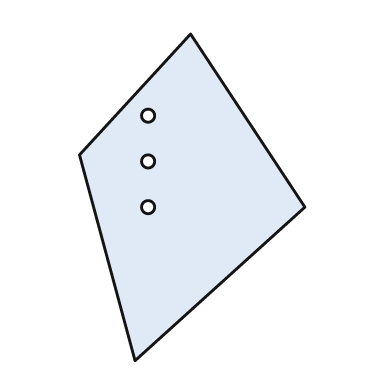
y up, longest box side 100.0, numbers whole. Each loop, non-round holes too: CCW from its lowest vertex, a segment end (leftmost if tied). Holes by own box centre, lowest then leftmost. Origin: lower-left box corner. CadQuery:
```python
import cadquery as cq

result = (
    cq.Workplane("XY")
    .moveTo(17.0, 0.0)
    .lineTo(69.0, 47.0)
    .lineTo(34.0, 100.0)
    .lineTo(0.0, 63.0)
    .close()
    .moveTo(21.0, 47.0)
    .circle(2.0)
    .moveTo(21.0, 61.0)
    .circle(2.0)
    .moveTo(21.0, 75.0)
    .circle(2.0)
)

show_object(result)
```